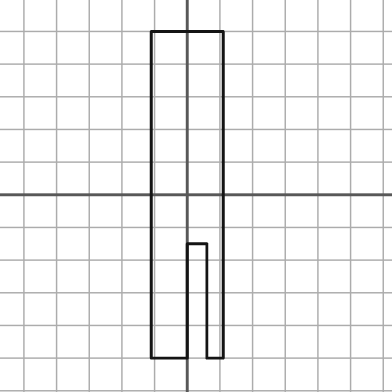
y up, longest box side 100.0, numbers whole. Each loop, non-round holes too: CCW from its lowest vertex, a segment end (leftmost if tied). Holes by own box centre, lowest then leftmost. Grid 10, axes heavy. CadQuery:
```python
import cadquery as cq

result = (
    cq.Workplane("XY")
    .moveTo(-11.0, -50.0)
    .lineTo(0.0, -50.0)
    .lineTo(0.0, -15.0)
    .lineTo(6.0, -15.0)
    .lineTo(6.0, -50.0)
    .lineTo(11.0, -50.0)
    .lineTo(11.0, 50.0)
    .lineTo(-11.0, 50.0)
    .close()
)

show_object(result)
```